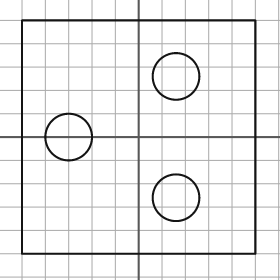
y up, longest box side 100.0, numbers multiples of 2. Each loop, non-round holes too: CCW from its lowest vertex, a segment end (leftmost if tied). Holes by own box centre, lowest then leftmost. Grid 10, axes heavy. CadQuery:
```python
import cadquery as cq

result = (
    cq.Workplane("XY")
    .moveTo(-50.0, -50.0)
    .lineTo(50.0, -50.0)
    .lineTo(50.0, 50.0)
    .lineTo(-50.0, 50.0)
    .close()
    .moveTo(16.0, -26.0)
    .circle(10.0)
    .moveTo(-30.0, 0.0)
    .circle(10.0)
    .moveTo(16.0, 26.0)
    .circle(10.0)
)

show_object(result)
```